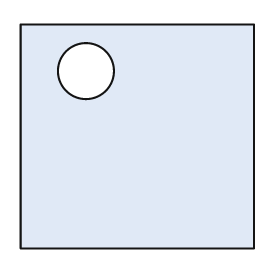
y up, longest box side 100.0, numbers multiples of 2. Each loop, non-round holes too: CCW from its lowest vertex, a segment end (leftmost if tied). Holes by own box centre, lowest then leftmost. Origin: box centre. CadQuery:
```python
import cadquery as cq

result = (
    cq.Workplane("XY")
    .moveTo(-50.0, -48.0)
    .lineTo(50.0, -48.0)
    .lineTo(50.0, 48.0)
    .lineTo(-50.0, 48.0)
    .close()
    .moveTo(-22.0, 28.0)
    .circle(12.0)
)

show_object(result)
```